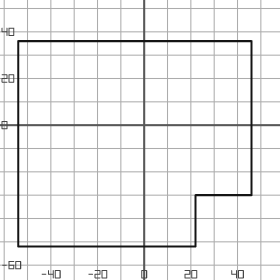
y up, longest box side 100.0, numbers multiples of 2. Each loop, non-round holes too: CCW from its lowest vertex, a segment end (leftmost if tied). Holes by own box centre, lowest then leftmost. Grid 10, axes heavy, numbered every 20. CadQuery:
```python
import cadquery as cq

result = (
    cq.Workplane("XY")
    .moveTo(-54.0, -52.0)
    .lineTo(22.0, -52.0)
    .lineTo(22.0, -30.0)
    .lineTo(46.0, -30.0)
    .lineTo(46.0, 36.0)
    .lineTo(-54.0, 36.0)
    .close()
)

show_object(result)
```